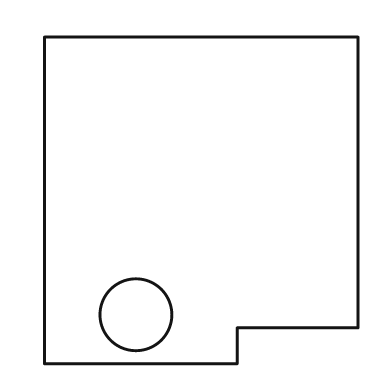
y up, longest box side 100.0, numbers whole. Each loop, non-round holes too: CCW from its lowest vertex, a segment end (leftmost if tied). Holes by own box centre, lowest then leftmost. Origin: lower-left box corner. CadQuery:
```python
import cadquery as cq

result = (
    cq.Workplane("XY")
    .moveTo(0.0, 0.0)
    .lineTo(59.0, 0.0)
    .lineTo(59.0, 11.0)
    .lineTo(96.0, 11.0)
    .lineTo(96.0, 100.0)
    .lineTo(0.0, 100.0)
    .close()
    .moveTo(28.0, 15.0)
    .circle(11.0)
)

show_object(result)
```